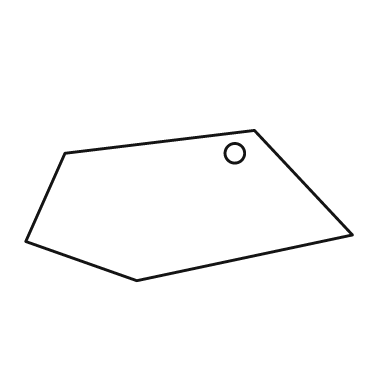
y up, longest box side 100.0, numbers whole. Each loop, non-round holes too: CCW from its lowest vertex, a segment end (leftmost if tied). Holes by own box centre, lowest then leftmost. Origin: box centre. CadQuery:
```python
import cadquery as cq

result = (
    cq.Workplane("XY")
    .moveTo(-16.0, -23.0)
    .lineTo(50.0, -9.0)
    .lineTo(20.0, 23.0)
    .lineTo(-38.0, 16.0)
    .lineTo(-50.0, -11.0)
    .close()
    .moveTo(14.0, 16.0)
    .circle(3.0)
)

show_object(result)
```